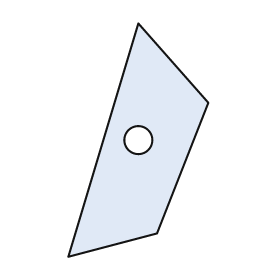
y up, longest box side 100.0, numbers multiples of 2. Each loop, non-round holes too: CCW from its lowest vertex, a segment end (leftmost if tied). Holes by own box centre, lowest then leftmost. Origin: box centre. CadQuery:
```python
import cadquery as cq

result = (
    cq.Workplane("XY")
    .moveTo(-30.0, -50.0)
    .lineTo(8.0, -40.0)
    .lineTo(30.0, 16.0)
    .lineTo(0.0, 50.0)
    .close()
    .moveTo(0.0, 0.0)
    .circle(6.0)
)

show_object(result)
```